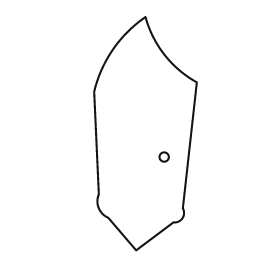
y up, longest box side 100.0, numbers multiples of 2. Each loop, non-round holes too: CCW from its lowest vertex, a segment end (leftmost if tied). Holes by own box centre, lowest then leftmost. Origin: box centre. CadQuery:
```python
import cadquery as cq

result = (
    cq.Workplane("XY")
    .moveTo(-4.0, -50.0)
    .lineTo(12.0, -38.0)
    .threePointArc((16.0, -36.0), (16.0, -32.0))
    .lineTo(22.0, 22.0)
    .threePointArc((8.0, 34.0), (0.0, 50.0))
    .threePointArc((-14.0, 36.0), (-22.0, 18.0))
    .lineTo(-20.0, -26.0)
    .threePointArc((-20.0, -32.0), (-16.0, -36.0))
    .close()
    .moveTo(8.0, -10.0)
    .circle(2.0)
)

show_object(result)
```